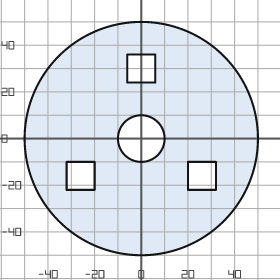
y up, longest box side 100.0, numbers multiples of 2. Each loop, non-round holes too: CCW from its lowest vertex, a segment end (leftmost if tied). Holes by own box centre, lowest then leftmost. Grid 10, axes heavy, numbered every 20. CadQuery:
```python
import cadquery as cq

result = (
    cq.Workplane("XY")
    .moveTo(0.0, 0.0)
    .circle(50.0)
    .moveTo(-32.0, -22.0)
    .lineTo(-20.0, -22.0)
    .lineTo(-20.0, -10.0)
    .lineTo(-32.0, -10.0)
    .close()
    .moveTo(20.0, -22.0)
    .lineTo(32.0, -22.0)
    .lineTo(32.0, -10.0)
    .lineTo(20.0, -10.0)
    .close()
    .moveTo(0.0, 0.0)
    .circle(10.0)
    .moveTo(-6.0, 24.0)
    .lineTo(6.0, 24.0)
    .lineTo(6.0, 36.0)
    .lineTo(-6.0, 36.0)
    .close()
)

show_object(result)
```